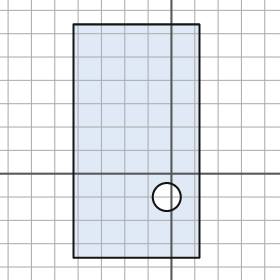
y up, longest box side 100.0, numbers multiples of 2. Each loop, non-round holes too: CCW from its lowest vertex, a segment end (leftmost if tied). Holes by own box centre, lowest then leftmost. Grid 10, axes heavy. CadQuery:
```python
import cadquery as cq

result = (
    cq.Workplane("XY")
    .moveTo(-42.0, -36.0)
    .lineTo(12.0, -36.0)
    .lineTo(12.0, 64.0)
    .lineTo(-42.0, 64.0)
    .close()
    .moveTo(-2.0, -10.0)
    .circle(6.0)
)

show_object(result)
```